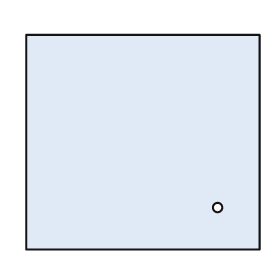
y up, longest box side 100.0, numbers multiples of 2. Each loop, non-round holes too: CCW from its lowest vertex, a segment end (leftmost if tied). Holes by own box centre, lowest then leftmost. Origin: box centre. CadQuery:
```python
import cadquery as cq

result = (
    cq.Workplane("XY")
    .moveTo(-50.0, -46.0)
    .lineTo(50.0, -46.0)
    .lineTo(50.0, 46.0)
    .lineTo(-50.0, 46.0)
    .close()
    .moveTo(32.0, -28.0)
    .circle(2.0)
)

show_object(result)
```